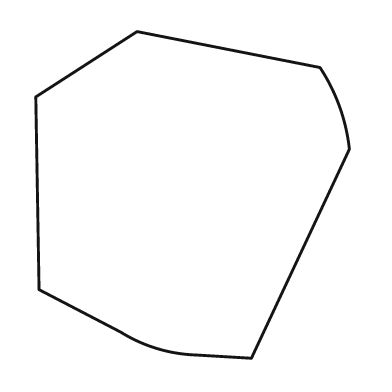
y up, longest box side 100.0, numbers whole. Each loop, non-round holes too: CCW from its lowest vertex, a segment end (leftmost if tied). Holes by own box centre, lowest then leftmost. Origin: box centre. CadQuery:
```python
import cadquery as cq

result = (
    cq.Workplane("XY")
    .moveTo(18.0, -50.0)
    .lineTo(48.0, 14.0)
    .threePointArc((45.0, 27.0), (39.0, 39.0))
    .lineTo(-17.0, 50.0)
    .lineTo(-48.0, 30.0)
    .lineTo(-47.0, -29.0)
    .lineTo(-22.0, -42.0)
    .threePointArc((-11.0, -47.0), (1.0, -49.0))
    .close()
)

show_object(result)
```